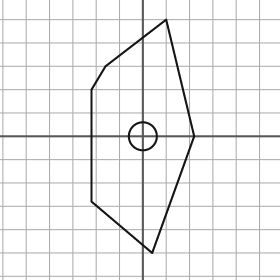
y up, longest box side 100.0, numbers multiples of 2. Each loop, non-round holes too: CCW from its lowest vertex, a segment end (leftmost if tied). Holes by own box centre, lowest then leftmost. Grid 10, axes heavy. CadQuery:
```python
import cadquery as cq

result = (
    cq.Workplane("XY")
    .moveTo(4.0, -50.0)
    .lineTo(22.0, 0.0)
    .lineTo(10.0, 50.0)
    .lineTo(-16.0, 30.0)
    .lineTo(-22.0, 20.0)
    .lineTo(-22.0, -28.0)
    .close()
    .moveTo(0.0, 0.0)
    .circle(6.0)
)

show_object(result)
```